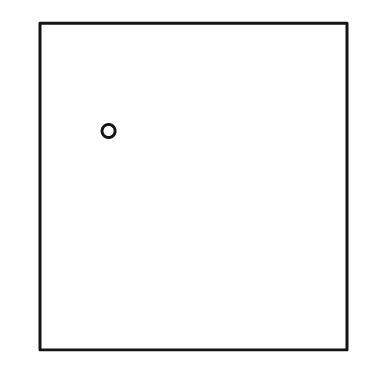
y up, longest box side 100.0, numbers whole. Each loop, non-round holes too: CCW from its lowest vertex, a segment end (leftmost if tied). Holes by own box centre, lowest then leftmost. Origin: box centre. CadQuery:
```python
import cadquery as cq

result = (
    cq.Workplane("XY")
    .moveTo(-47.0, -50.0)
    .lineTo(47.0, -50.0)
    .lineTo(47.0, 50.0)
    .lineTo(-47.0, 50.0)
    .close()
    .moveTo(-26.0, 17.0)
    .circle(2.0)
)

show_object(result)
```